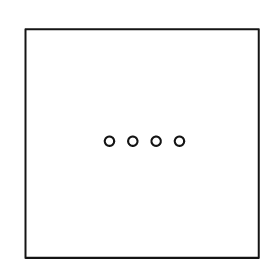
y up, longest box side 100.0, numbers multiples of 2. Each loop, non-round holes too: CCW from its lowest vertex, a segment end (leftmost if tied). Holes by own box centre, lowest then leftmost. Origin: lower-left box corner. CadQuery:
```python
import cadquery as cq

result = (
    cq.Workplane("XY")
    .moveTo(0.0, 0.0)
    .lineTo(100.0, 0.0)
    .lineTo(100.0, 98.0)
    .lineTo(0.0, 98.0)
    .close()
    .moveTo(36.0, 50.0)
    .circle(2.0)
    .moveTo(46.0, 50.0)
    .circle(2.0)
    .moveTo(56.0, 50.0)
    .circle(2.0)
    .moveTo(66.0, 50.0)
    .circle(2.0)
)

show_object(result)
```